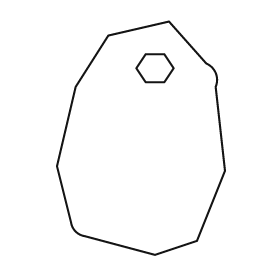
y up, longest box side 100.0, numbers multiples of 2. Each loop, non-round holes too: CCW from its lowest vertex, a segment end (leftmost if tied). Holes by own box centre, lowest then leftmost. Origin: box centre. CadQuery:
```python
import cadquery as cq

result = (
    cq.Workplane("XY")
    .moveTo(6.0, -50.0)
    .lineTo(24.0, -44.0)
    .lineTo(36.0, -14.0)
    .lineTo(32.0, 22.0)
    .threePointArc((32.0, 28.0), (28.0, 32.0))
    .lineTo(12.0, 50.0)
    .lineTo(-14.0, 44.0)
    .lineTo(-28.0, 22.0)
    .lineTo(-36.0, -12.0)
    .lineTo(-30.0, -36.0)
    .threePointArc((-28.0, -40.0), (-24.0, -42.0))
    .close()
    .moveTo(2.0, 24.0)
    .lineTo(10.0, 24.0)
    .lineTo(14.0, 30.0)
    .lineTo(10.0, 36.0)
    .lineTo(2.0, 36.0)
    .lineTo(-2.0, 30.0)
    .close()
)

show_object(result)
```